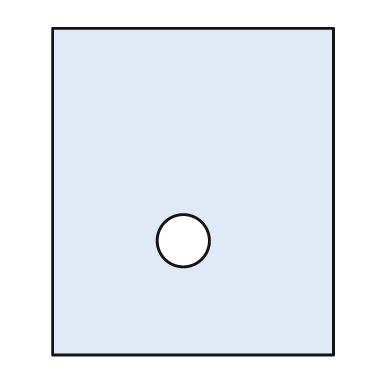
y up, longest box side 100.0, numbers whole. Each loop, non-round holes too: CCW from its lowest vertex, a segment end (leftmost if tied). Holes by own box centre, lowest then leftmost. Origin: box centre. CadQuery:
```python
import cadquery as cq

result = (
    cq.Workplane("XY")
    .moveTo(-43.0, -50.0)
    .lineTo(43.0, -50.0)
    .lineTo(43.0, 50.0)
    .lineTo(-43.0, 50.0)
    .close()
    .moveTo(-3.0, -15.0)
    .circle(8.0)
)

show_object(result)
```